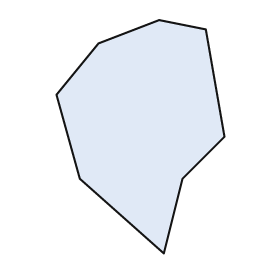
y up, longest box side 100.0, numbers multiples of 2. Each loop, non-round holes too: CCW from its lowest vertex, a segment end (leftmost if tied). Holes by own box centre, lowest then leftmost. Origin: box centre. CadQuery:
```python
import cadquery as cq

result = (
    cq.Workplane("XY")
    .moveTo(10.0, -50.0)
    .lineTo(18.0, -18.0)
    .lineTo(36.0, 0.0)
    .lineTo(28.0, 46.0)
    .lineTo(8.0, 50.0)
    .lineTo(-18.0, 40.0)
    .lineTo(-36.0, 18.0)
    .lineTo(-26.0, -18.0)
    .close()
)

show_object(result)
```